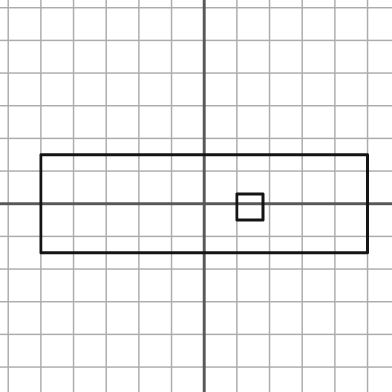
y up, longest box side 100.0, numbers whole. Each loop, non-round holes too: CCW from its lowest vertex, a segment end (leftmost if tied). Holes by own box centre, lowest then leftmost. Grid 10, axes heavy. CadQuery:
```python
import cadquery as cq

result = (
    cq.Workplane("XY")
    .moveTo(-50.0, -15.0)
    .lineTo(50.0, -15.0)
    .lineTo(50.0, 15.0)
    .lineTo(-50.0, 15.0)
    .close()
    .moveTo(10.0, -5.0)
    .lineTo(18.0, -5.0)
    .lineTo(18.0, 3.0)
    .lineTo(10.0, 3.0)
    .close()
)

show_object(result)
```